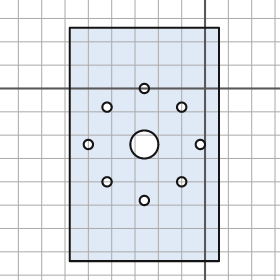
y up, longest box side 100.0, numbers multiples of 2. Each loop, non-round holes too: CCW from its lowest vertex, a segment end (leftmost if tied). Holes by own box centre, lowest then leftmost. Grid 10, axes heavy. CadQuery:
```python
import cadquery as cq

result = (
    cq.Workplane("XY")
    .moveTo(-58.0, -74.0)
    .lineTo(6.0, -74.0)
    .lineTo(6.0, 26.0)
    .lineTo(-58.0, 26.0)
    .close()
    .moveTo(-26.0, -48.0)
    .circle(2.0)
    .moveTo(-42.0, -40.0)
    .circle(2.0)
    .moveTo(-10.0, -40.0)
    .circle(2.0)
    .moveTo(-50.0, -24.0)
    .circle(2.0)
    .moveTo(-26.0, -24.0)
    .circle(6.0)
    .moveTo(-2.0, -24.0)
    .circle(2.0)
    .moveTo(-42.0, -8.0)
    .circle(2.0)
    .moveTo(-10.0, -8.0)
    .circle(2.0)
    .moveTo(-26.0, 0.0)
    .circle(2.0)
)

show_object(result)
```